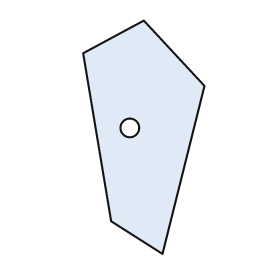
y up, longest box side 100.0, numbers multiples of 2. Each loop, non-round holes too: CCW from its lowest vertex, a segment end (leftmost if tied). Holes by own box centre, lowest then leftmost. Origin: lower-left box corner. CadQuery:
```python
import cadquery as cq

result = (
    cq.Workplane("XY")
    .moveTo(34.0, 0.0)
    .lineTo(52.0, 72.0)
    .lineTo(26.0, 100.0)
    .lineTo(0.0, 86.0)
    .lineTo(12.0, 14.0)
    .close()
    .moveTo(20.0, 54.0)
    .circle(4.0)
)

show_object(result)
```